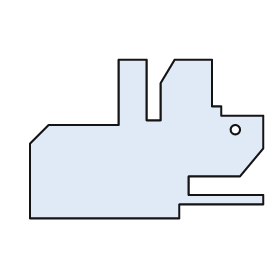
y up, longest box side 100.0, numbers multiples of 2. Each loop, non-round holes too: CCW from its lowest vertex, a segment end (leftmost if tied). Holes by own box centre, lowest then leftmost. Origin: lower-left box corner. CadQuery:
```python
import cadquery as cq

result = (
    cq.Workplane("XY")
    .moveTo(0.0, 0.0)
    .lineTo(64.0, 0.0)
    .lineTo(64.0, 6.0)
    .lineTo(100.0, 6.0)
    .lineTo(100.0, 10.0)
    .lineTo(68.0, 10.0)
    .lineTo(68.0, 18.0)
    .lineTo(90.0, 18.0)
    .lineTo(100.0, 30.0)
    .lineTo(100.0, 44.0)
    .lineTo(82.0, 44.0)
    .lineTo(82.0, 48.0)
    .lineTo(78.0, 48.0)
    .lineTo(78.0, 68.0)
    .lineTo(62.0, 68.0)
    .lineTo(56.0, 58.0)
    .lineTo(56.0, 42.0)
    .lineTo(50.0, 42.0)
    .lineTo(50.0, 68.0)
    .lineTo(38.0, 68.0)
    .lineTo(38.0, 40.0)
    .lineTo(8.0, 40.0)
    .lineTo(0.0, 32.0)
    .close()
    .moveTo(88.0, 38.0)
    .circle(2.0)
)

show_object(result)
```